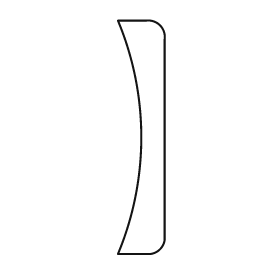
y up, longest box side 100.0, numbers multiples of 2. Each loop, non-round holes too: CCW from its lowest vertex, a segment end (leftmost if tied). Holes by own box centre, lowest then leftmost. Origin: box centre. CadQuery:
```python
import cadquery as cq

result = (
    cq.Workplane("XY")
    .moveTo(-10.0, -50.0)
    .lineTo(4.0, -50.0)
    .threePointArc((8.0, -48.0), (10.0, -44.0))
    .lineTo(10.0, 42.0)
    .threePointArc((8.0, 48.0), (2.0, 50.0))
    .lineTo(-10.0, 50.0)
    .threePointArc((0.0, 0.0), (-10.0, -50.0))
    .close()
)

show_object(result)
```